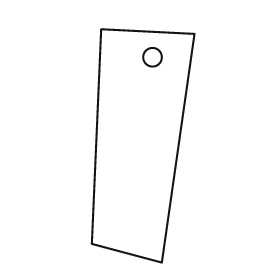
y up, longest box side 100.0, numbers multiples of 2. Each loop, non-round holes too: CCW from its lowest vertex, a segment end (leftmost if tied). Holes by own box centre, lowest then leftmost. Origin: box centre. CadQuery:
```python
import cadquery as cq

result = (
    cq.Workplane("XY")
    .moveTo(8.0, -50.0)
    .lineTo(22.0, 48.0)
    .lineTo(-18.0, 50.0)
    .lineTo(-22.0, -42.0)
    .close()
    .moveTo(4.0, 38.0)
    .circle(4.0)
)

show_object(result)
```